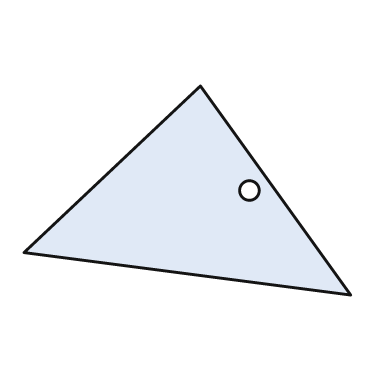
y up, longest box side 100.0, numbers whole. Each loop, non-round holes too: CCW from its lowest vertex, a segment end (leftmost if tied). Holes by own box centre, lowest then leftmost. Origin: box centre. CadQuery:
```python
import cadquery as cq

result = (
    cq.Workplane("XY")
    .moveTo(50.0, -32.0)
    .lineTo(4.0, 32.0)
    .lineTo(-50.0, -19.0)
    .close()
    .moveTo(19.0, 0.0)
    .circle(3.0)
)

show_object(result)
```